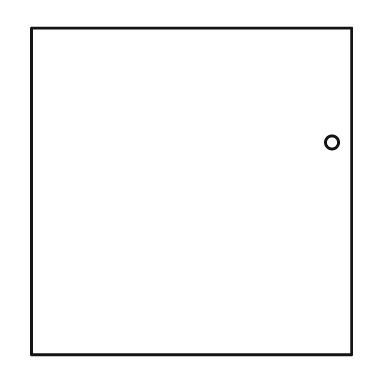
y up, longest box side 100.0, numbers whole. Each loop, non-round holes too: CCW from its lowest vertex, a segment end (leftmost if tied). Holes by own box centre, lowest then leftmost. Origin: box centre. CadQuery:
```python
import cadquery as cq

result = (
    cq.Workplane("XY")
    .moveTo(-49.0, -50.0)
    .lineTo(49.0, -50.0)
    .lineTo(49.0, 50.0)
    .lineTo(-49.0, 50.0)
    .close()
    .moveTo(43.0, 15.0)
    .circle(2.0)
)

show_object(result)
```